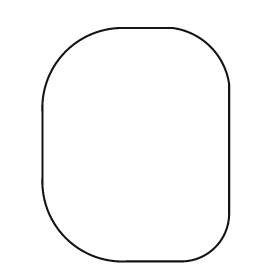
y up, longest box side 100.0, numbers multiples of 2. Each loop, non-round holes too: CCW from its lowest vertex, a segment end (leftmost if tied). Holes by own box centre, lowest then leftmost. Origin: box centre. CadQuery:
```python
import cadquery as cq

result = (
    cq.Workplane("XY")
    .moveTo(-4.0, -50.0)
    .lineTo(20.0, -50.0)
    .threePointArc((34.0, -44.0), (40.0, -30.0))
    .lineTo(40.0, 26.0)
    .threePointArc((32.0, 42.0), (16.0, 50.0))
    .lineTo(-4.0, 50.0)
    .threePointArc((-30.0, 40.0), (-40.0, 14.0))
    .lineTo(-40.0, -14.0)
    .threePointArc((-30.0, -40.0), (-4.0, -50.0))
    .close()
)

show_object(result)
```